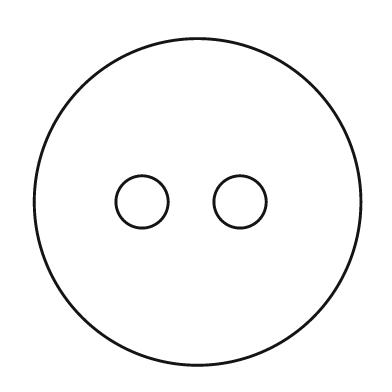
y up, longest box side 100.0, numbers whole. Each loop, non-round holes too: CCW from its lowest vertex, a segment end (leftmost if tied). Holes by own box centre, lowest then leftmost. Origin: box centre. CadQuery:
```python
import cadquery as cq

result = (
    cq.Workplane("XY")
    .moveTo(0.0, 0.0)
    .circle(50.0)
    .moveTo(-17.0, 0.0)
    .circle(8.0)
    .moveTo(13.0, 0.0)
    .circle(8.0)
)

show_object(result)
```